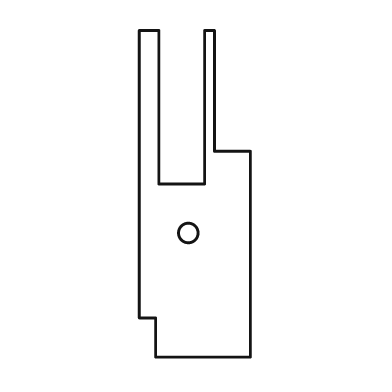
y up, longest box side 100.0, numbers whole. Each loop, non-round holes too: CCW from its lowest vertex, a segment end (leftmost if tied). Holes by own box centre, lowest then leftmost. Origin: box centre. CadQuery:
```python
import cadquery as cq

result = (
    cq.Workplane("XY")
    .moveTo(-12.0, -50.0)
    .lineTo(17.0, -50.0)
    .lineTo(17.0, 13.0)
    .lineTo(6.0, 13.0)
    .lineTo(6.0, 50.0)
    .lineTo(3.0, 50.0)
    .lineTo(3.0, 3.0)
    .lineTo(-11.0, 3.0)
    .lineTo(-11.0, 50.0)
    .lineTo(-17.0, 50.0)
    .lineTo(-17.0, -38.0)
    .lineTo(-12.0, -38.0)
    .close()
    .moveTo(-2.0, -12.0)
    .circle(3.0)
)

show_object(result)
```